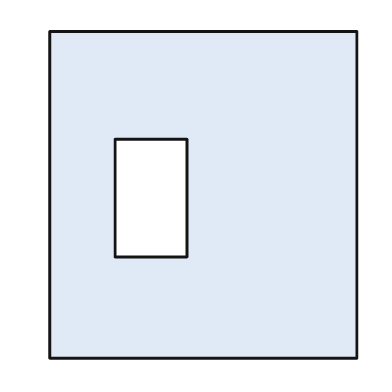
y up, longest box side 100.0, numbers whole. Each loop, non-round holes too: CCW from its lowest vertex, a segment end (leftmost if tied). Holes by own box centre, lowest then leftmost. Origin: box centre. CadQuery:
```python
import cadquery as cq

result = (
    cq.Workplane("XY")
    .moveTo(-47.0, -50.0)
    .lineTo(47.0, -50.0)
    .lineTo(47.0, 50.0)
    .lineTo(-47.0, 50.0)
    .close()
    .moveTo(-27.0, -19.0)
    .lineTo(-5.0, -19.0)
    .lineTo(-5.0, 17.0)
    .lineTo(-27.0, 17.0)
    .close()
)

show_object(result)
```